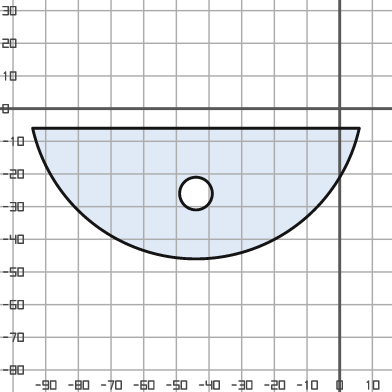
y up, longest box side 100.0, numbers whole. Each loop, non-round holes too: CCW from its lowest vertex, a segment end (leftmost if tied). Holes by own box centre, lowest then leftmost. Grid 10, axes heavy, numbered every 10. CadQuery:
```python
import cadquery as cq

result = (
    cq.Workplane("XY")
    .moveTo(-94.0, -6.0)
    .threePointArc((-44.0, -46.0), (6.0, -6.0))
    .close()
    .moveTo(-44.0, -26.0)
    .circle(5.0)
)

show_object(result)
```